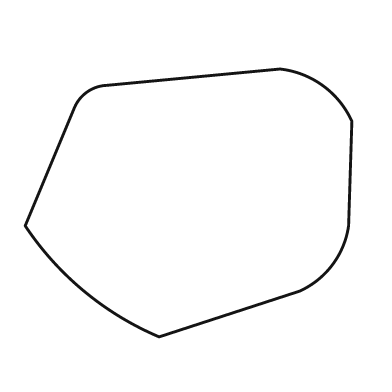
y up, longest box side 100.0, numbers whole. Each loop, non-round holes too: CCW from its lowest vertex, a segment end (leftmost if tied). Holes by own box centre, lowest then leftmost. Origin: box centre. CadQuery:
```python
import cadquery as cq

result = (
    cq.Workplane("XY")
    .moveTo(-9.0, -41.0)
    .lineTo(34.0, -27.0)
    .threePointArc((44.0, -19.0), (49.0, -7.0))
    .lineTo(50.0, 25.0)
    .threePointArc((41.0, 36.0), (28.0, 41.0))
    .lineTo(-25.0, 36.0)
    .threePointArc((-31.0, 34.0), (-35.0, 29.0))
    .lineTo(-50.0, -7.0)
    .threePointArc((-32.0, -27.0), (-9.0, -41.0))
    .close()
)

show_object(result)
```